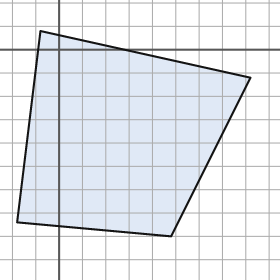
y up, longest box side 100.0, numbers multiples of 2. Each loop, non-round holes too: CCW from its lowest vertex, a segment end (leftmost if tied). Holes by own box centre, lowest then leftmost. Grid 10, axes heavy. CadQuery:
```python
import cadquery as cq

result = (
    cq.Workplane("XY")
    .moveTo(48.0, -80.0)
    .lineTo(82.0, -12.0)
    .lineTo(-8.0, 8.0)
    .lineTo(-18.0, -74.0)
    .close()
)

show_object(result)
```